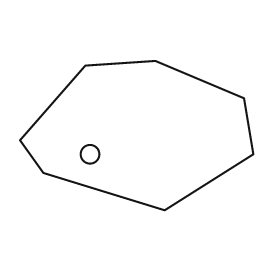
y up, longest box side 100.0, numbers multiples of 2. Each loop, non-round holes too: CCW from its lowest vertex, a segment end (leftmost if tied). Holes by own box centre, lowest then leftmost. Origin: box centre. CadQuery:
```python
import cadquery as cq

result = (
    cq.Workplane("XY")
    .moveTo(12.0, -32.0)
    .lineTo(50.0, -8.0)
    .lineTo(46.0, 16.0)
    .lineTo(8.0, 32.0)
    .lineTo(-22.0, 30.0)
    .lineTo(-50.0, -2.0)
    .lineTo(-40.0, -16.0)
    .close()
    .moveTo(-20.0, -8.0)
    .circle(4.0)
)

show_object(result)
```